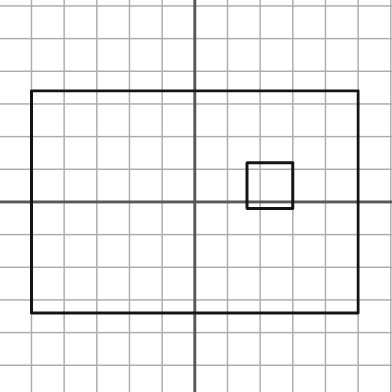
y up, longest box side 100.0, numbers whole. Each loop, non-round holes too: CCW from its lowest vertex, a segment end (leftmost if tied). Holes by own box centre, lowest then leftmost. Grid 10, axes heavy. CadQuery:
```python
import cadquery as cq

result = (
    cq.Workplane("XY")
    .moveTo(-50.0, -34.0)
    .lineTo(50.0, -34.0)
    .lineTo(50.0, 34.0)
    .lineTo(-50.0, 34.0)
    .close()
    .moveTo(16.0, -2.0)
    .lineTo(30.0, -2.0)
    .lineTo(30.0, 12.0)
    .lineTo(16.0, 12.0)
    .close()
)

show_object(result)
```